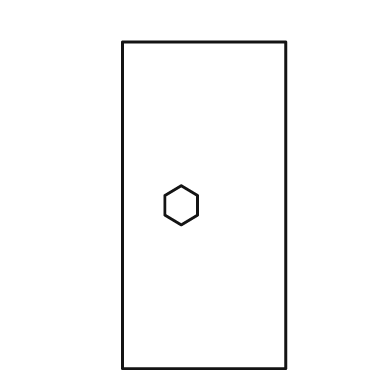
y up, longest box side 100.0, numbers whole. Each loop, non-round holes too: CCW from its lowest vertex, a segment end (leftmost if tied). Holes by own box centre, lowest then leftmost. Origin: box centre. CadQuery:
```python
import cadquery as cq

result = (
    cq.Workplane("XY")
    .moveTo(-25.0, -50.0)
    .lineTo(25.0, -50.0)
    .lineTo(25.0, 50.0)
    .lineTo(-25.0, 50.0)
    .close()
    .moveTo(-7.0, -6.0)
    .lineTo(-2.0, -3.0)
    .lineTo(-2.0, 3.0)
    .lineTo(-7.0, 6.0)
    .lineTo(-12.0, 3.0)
    .lineTo(-12.0, -3.0)
    .close()
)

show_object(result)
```